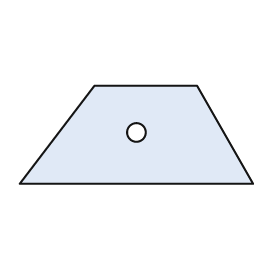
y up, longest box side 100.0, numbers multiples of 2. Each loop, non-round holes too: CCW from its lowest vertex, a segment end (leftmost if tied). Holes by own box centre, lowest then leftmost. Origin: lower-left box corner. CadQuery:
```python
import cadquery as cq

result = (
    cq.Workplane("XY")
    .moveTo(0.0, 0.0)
    .lineTo(100.0, 0.0)
    .lineTo(76.0, 42.0)
    .lineTo(32.0, 42.0)
    .close()
    .moveTo(50.0, 22.0)
    .circle(4.0)
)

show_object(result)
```